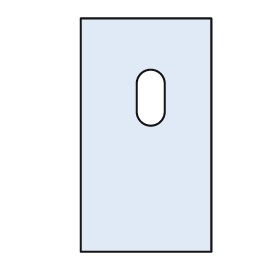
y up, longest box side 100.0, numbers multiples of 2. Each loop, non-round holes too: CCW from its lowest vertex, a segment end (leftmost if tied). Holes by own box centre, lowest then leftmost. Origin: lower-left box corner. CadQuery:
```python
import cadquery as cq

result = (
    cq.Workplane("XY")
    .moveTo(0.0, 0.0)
    .lineTo(56.0, 0.0)
    .lineTo(56.0, 100.0)
    .lineTo(0.0, 100.0)
    .close()
    .moveTo(24.0, 60.0)
    .threePointArc((30.0, 54.0), (36.0, 60.0))
    .lineTo(36.0, 72.0)
    .threePointArc((30.0, 78.0), (24.0, 72.0))
    .close()
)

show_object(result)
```